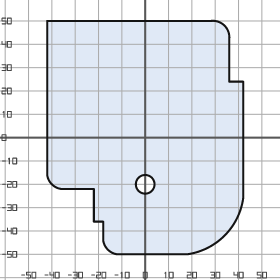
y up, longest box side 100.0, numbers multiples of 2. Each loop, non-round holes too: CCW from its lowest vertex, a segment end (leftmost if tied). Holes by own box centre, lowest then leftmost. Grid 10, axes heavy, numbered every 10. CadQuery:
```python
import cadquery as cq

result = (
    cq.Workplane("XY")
    .moveTo(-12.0, -50.0)
    .lineTo(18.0, -50.0)
    .threePointArc((34.0, -42.0), (42.0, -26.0))
    .lineTo(42.0, 24.0)
    .lineTo(36.0, 24.0)
    .lineTo(36.0, 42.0)
    .threePointArc((34.0, 48.0), (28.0, 50.0))
    .lineTo(-42.0, 50.0)
    .lineTo(-42.0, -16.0)
    .threePointArc((-40.0, -20.0), (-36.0, -22.0))
    .lineTo(-22.0, -22.0)
    .lineTo(-22.0, -36.0)
    .lineTo(-18.0, -36.0)
    .lineTo(-18.0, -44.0)
    .threePointArc((-16.0, -48.0), (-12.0, -50.0))
    .close()
    .moveTo(0.0, -20.0)
    .circle(4.0)
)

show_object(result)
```